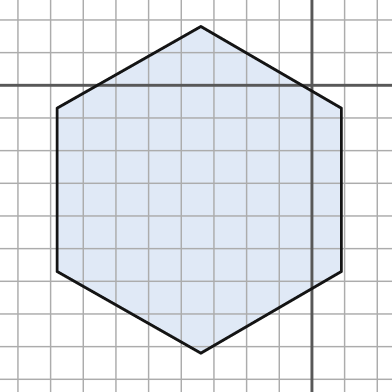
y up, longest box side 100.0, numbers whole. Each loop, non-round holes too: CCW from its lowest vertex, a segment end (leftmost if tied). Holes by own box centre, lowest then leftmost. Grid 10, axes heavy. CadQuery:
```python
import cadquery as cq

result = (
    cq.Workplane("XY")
    .moveTo(-34.0, -82.0)
    .lineTo(9.0, -57.0)
    .lineTo(9.0, -7.0)
    .lineTo(-34.0, 18.0)
    .lineTo(-78.0, -7.0)
    .lineTo(-78.0, -57.0)
    .close()
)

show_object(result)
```